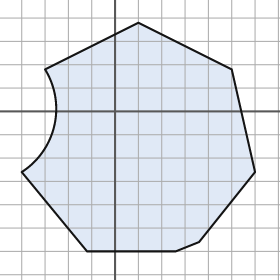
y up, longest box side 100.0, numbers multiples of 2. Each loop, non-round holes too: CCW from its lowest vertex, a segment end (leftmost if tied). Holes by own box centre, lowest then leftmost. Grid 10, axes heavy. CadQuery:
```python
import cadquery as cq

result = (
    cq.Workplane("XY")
    .moveTo(-12.0, -60.0)
    .lineTo(26.0, -60.0)
    .lineTo(36.0, -56.0)
    .lineTo(60.0, -26.0)
    .lineTo(50.0, 18.0)
    .lineTo(10.0, 38.0)
    .lineTo(-30.0, 18.0)
    .threePointArc((-26.0, -6.0), (-40.0, -26.0))
    .close()
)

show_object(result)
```